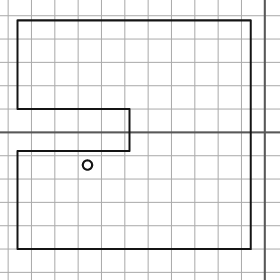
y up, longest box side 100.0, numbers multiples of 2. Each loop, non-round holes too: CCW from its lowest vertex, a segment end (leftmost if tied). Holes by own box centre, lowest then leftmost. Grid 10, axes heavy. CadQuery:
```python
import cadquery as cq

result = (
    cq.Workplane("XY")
    .moveTo(-106.0, -50.0)
    .lineTo(-6.0, -50.0)
    .lineTo(-6.0, 48.0)
    .lineTo(-106.0, 48.0)
    .lineTo(-106.0, 10.0)
    .lineTo(-58.0, 10.0)
    .lineTo(-58.0, -8.0)
    .lineTo(-106.0, -8.0)
    .close()
    .moveTo(-76.0, -14.0)
    .circle(2.0)
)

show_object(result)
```